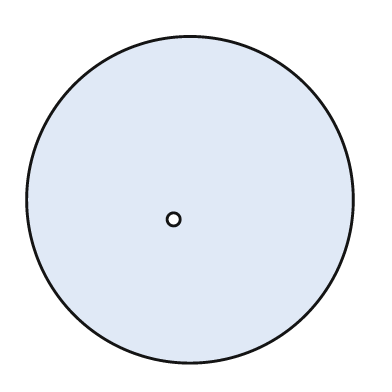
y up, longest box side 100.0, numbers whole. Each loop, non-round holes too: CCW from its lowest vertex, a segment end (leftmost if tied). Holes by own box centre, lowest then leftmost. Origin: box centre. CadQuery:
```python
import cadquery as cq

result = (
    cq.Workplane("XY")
    .moveTo(0.0, 0.0)
    .circle(50.0)
    .moveTo(-5.0, -6.0)
    .circle(2.0)
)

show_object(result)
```